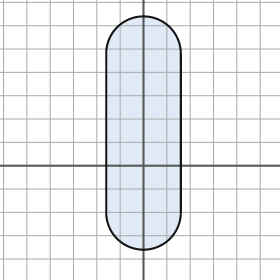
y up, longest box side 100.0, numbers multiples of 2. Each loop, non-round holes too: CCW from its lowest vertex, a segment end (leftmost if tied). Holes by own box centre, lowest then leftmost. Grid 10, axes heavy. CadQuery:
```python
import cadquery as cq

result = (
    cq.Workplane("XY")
    .moveTo(-16.0, -20.0)
    .threePointArc((0.0, -36.0), (16.0, -20.0))
    .lineTo(16.0, 48.0)
    .threePointArc((0.0, 64.0), (-16.0, 48.0))
    .close()
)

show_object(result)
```